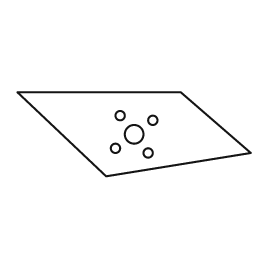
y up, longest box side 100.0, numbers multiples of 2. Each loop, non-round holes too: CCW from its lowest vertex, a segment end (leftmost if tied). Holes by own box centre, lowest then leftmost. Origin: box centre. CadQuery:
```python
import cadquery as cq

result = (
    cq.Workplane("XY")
    .moveTo(-12.0, -18.0)
    .lineTo(50.0, -8.0)
    .lineTo(20.0, 18.0)
    .lineTo(-50.0, 18.0)
    .close()
    .moveTo(6.0, -8.0)
    .circle(2.0)
    .moveTo(-8.0, -6.0)
    .circle(2.0)
    .moveTo(0.0, 0.0)
    .circle(4.0)
    .moveTo(8.0, 6.0)
    .circle(2.0)
    .moveTo(-6.0, 8.0)
    .circle(2.0)
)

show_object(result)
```